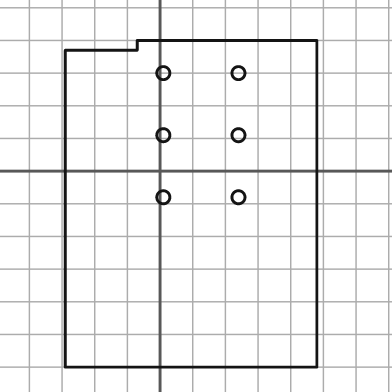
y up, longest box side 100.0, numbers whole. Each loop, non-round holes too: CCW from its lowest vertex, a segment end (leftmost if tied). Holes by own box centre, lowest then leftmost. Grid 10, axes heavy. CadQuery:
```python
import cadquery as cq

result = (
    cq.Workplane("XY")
    .moveTo(-29.0, -60.0)
    .lineTo(48.0, -60.0)
    .lineTo(48.0, 40.0)
    .lineTo(-7.0, 40.0)
    .lineTo(-7.0, 37.0)
    .lineTo(-29.0, 37.0)
    .close()
    .moveTo(1.0, -8.0)
    .circle(2.0)
    .moveTo(24.0, -8.0)
    .circle(2.0)
    .moveTo(1.0, 11.0)
    .circle(2.0)
    .moveTo(24.0, 11.0)
    .circle(2.0)
    .moveTo(1.0, 30.0)
    .circle(2.0)
    .moveTo(24.0, 30.0)
    .circle(2.0)
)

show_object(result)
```